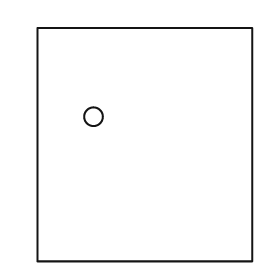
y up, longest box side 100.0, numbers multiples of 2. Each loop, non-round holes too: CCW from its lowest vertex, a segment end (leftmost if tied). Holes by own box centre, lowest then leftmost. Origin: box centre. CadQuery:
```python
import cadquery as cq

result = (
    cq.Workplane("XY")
    .moveTo(-46.0, -50.0)
    .lineTo(46.0, -50.0)
    .lineTo(46.0, 50.0)
    .lineTo(-46.0, 50.0)
    .close()
    .moveTo(-22.0, 12.0)
    .circle(4.0)
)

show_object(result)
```